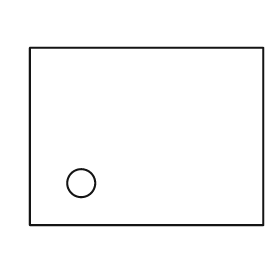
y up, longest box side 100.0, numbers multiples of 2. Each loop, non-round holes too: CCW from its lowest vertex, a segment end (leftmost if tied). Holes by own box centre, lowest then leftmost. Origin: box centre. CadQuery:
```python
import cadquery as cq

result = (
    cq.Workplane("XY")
    .moveTo(-50.0, -38.0)
    .lineTo(50.0, -38.0)
    .lineTo(50.0, 38.0)
    .lineTo(-50.0, 38.0)
    .close()
    .moveTo(-28.0, -20.0)
    .circle(6.0)
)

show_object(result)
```